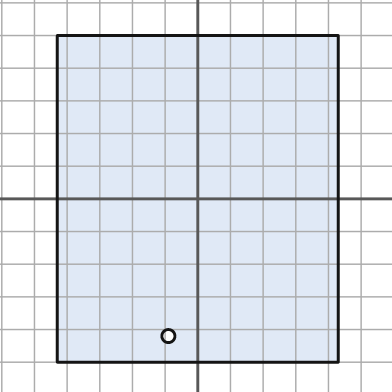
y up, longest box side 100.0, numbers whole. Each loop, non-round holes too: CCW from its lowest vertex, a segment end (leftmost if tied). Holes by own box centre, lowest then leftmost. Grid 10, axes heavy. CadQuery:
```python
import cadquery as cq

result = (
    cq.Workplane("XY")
    .moveTo(-43.0, -50.0)
    .lineTo(43.0, -50.0)
    .lineTo(43.0, 50.0)
    .lineTo(-43.0, 50.0)
    .close()
    .moveTo(-9.0, -42.0)
    .circle(2.0)
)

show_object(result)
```